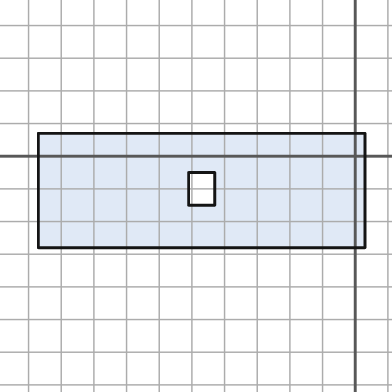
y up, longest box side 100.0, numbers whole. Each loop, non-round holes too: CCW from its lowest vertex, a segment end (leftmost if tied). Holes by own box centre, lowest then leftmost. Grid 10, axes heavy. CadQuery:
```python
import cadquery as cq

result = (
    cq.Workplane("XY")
    .moveTo(-97.0, -28.0)
    .lineTo(3.0, -28.0)
    .lineTo(3.0, 7.0)
    .lineTo(-97.0, 7.0)
    .close()
    .moveTo(-51.0, -15.0)
    .lineTo(-43.0, -15.0)
    .lineTo(-43.0, -5.0)
    .lineTo(-51.0, -5.0)
    .close()
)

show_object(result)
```